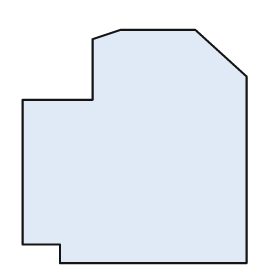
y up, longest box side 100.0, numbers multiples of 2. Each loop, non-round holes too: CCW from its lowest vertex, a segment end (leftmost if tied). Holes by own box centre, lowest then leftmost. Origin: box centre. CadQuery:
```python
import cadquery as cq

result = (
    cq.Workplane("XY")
    .moveTo(-32.0, -50.0)
    .lineTo(48.0, -50.0)
    .lineTo(48.0, 30.0)
    .lineTo(26.0, 50.0)
    .lineTo(-6.0, 50.0)
    .lineTo(-18.0, 46.0)
    .lineTo(-18.0, 20.0)
    .lineTo(-48.0, 20.0)
    .lineTo(-48.0, -42.0)
    .lineTo(-32.0, -42.0)
    .close()
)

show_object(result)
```